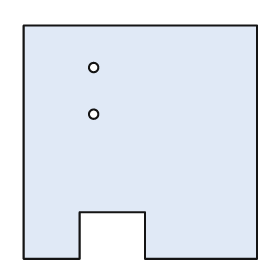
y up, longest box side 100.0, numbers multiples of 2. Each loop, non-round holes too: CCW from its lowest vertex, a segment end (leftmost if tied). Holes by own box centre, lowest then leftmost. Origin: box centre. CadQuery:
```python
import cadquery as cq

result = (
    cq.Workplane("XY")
    .moveTo(-50.0, -50.0)
    .lineTo(-26.0, -50.0)
    .lineTo(-26.0, -30.0)
    .lineTo(2.0, -30.0)
    .lineTo(2.0, -50.0)
    .lineTo(50.0, -50.0)
    .lineTo(50.0, 50.0)
    .lineTo(-50.0, 50.0)
    .close()
    .moveTo(-20.0, 12.0)
    .circle(2.0)
    .moveTo(-20.0, 32.0)
    .circle(2.0)
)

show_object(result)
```